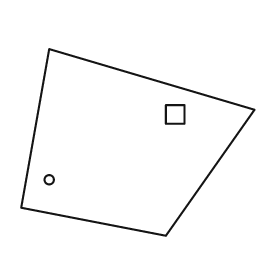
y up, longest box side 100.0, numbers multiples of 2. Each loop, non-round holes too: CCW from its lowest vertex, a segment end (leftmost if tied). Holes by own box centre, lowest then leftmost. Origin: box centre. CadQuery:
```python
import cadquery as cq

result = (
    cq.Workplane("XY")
    .moveTo(12.0, -40.0)
    .lineTo(50.0, 14.0)
    .lineTo(-38.0, 40.0)
    .lineTo(-50.0, -28.0)
    .close()
    .moveTo(-38.0, -16.0)
    .circle(2.0)
    .moveTo(12.0, 8.0)
    .lineTo(20.0, 8.0)
    .lineTo(20.0, 16.0)
    .lineTo(12.0, 16.0)
    .close()
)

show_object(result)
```